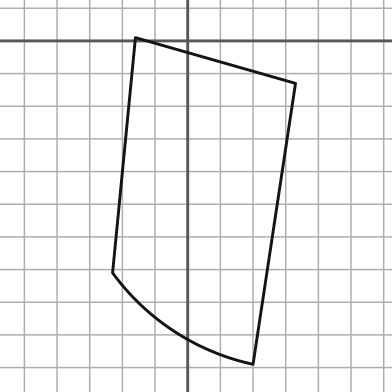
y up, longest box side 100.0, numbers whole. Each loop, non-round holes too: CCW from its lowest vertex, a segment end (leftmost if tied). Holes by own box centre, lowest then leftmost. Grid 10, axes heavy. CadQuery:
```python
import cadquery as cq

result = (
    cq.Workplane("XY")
    .moveTo(20.0, -99.0)
    .lineTo(33.0, -13.0)
    .lineTo(-16.0, 1.0)
    .lineTo(-23.0, -71.0)
    .threePointArc((-4.0, -89.0), (20.0, -99.0))
    .close()
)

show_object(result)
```